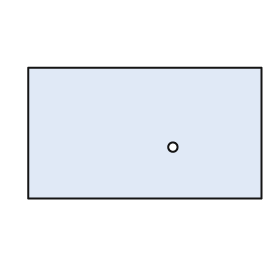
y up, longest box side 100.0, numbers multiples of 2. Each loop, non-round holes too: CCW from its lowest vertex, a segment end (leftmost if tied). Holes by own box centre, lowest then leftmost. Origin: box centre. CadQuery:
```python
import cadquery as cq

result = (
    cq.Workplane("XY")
    .moveTo(-50.0, -28.0)
    .lineTo(50.0, -28.0)
    .lineTo(50.0, 28.0)
    .lineTo(-50.0, 28.0)
    .close()
    .moveTo(12.0, -6.0)
    .circle(2.0)
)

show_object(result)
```